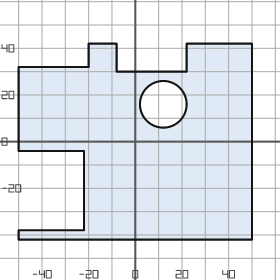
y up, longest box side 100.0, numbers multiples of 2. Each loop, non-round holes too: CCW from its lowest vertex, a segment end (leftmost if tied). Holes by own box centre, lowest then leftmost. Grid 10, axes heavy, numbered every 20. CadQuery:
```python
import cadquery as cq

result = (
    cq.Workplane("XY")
    .moveTo(-50.0, -42.0)
    .lineTo(50.0, -42.0)
    .lineTo(50.0, 42.0)
    .lineTo(22.0, 42.0)
    .lineTo(22.0, 30.0)
    .lineTo(-8.0, 30.0)
    .lineTo(-8.0, 42.0)
    .lineTo(-20.0, 42.0)
    .lineTo(-20.0, 32.0)
    .lineTo(-50.0, 32.0)
    .lineTo(-50.0, -4.0)
    .lineTo(-22.0, -4.0)
    .lineTo(-22.0, -38.0)
    .lineTo(-50.0, -38.0)
    .close()
    .moveTo(12.0, 16.0)
    .circle(10.0)
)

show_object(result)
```